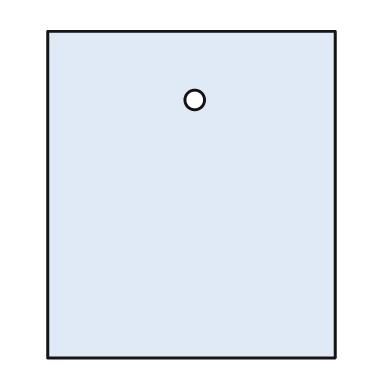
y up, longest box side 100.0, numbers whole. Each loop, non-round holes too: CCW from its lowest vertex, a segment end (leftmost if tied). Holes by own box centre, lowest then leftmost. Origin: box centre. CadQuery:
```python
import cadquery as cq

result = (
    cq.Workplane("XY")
    .moveTo(-44.0, -50.0)
    .lineTo(44.0, -50.0)
    .lineTo(44.0, 50.0)
    .lineTo(-44.0, 50.0)
    .close()
    .moveTo(1.0, 29.0)
    .circle(3.0)
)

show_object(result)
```